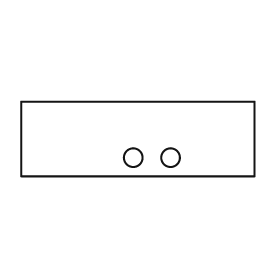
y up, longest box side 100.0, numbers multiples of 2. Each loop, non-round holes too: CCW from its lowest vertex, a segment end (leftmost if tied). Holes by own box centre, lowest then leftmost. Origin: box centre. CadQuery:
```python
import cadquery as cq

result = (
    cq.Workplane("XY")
    .moveTo(-50.0, -16.0)
    .lineTo(50.0, -16.0)
    .lineTo(50.0, 16.0)
    .lineTo(-50.0, 16.0)
    .close()
    .moveTo(-2.0, -8.0)
    .circle(4.0)
    .moveTo(14.0, -8.0)
    .circle(4.0)
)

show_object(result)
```